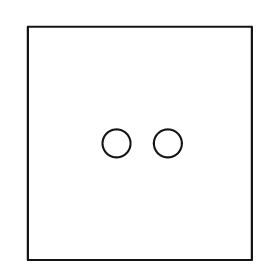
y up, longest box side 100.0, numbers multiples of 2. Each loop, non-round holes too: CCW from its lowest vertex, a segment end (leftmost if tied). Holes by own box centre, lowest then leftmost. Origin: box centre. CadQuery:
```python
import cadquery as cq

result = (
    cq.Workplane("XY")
    .moveTo(-48.0, -50.0)
    .lineTo(48.0, -50.0)
    .lineTo(48.0, 50.0)
    .lineTo(-48.0, 50.0)
    .close()
    .moveTo(-10.0, 0.0)
    .circle(6.0)
    .moveTo(12.0, 0.0)
    .circle(6.0)
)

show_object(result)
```